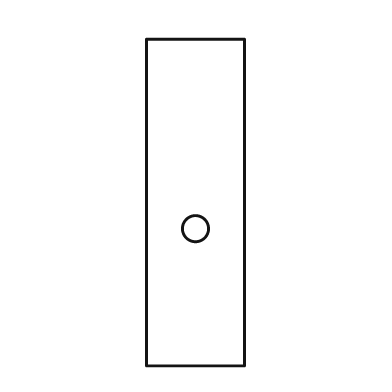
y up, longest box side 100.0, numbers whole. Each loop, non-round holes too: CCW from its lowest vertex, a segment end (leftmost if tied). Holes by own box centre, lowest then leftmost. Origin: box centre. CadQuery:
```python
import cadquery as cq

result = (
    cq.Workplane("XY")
    .moveTo(-15.0, -50.0)
    .lineTo(15.0, -50.0)
    .lineTo(15.0, 50.0)
    .lineTo(-15.0, 50.0)
    .close()
    .moveTo(0.0, -8.0)
    .circle(4.0)
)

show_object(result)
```